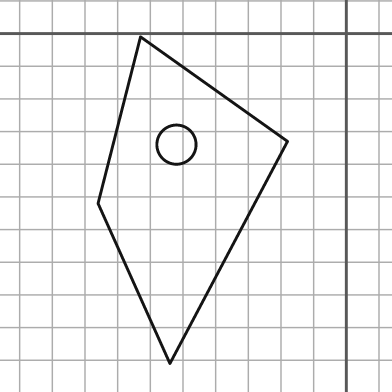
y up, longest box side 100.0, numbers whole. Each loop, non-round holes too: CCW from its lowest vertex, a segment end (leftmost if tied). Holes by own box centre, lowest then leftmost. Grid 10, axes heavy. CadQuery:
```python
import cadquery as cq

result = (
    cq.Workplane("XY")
    .moveTo(-54.0, -101.0)
    .lineTo(-18.0, -33.0)
    .lineTo(-63.0, -1.0)
    .lineTo(-76.0, -52.0)
    .close()
    .moveTo(-52.0, -34.0)
    .circle(6.0)
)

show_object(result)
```